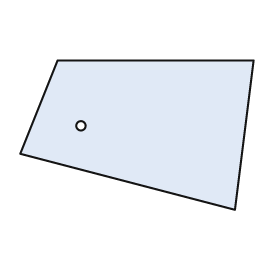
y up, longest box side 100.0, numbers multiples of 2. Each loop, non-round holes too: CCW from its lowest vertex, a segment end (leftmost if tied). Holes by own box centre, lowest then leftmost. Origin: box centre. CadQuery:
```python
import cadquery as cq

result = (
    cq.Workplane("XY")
    .moveTo(42.0, -32.0)
    .lineTo(50.0, 32.0)
    .lineTo(-34.0, 32.0)
    .lineTo(-50.0, -8.0)
    .close()
    .moveTo(-24.0, 4.0)
    .circle(2.0)
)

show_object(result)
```